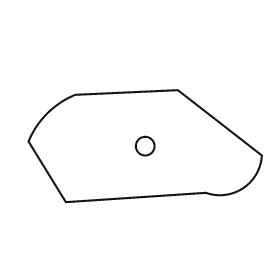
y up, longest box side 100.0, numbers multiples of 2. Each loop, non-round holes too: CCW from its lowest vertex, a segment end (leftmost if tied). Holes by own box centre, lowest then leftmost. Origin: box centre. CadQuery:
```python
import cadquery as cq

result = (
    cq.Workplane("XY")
    .moveTo(-34.0, -24.0)
    .lineTo(26.0, -20.0)
    .threePointArc((42.0, -18.0), (50.0, -4.0))
    .lineTo(14.0, 24.0)
    .lineTo(-30.0, 22.0)
    .threePointArc((-42.0, 14.0), (-50.0, 2.0))
    .close()
    .moveTo(0.0, 0.0)
    .circle(4.0)
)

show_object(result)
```